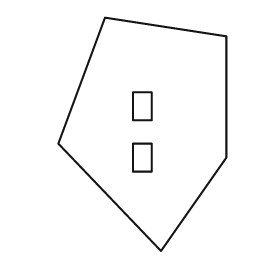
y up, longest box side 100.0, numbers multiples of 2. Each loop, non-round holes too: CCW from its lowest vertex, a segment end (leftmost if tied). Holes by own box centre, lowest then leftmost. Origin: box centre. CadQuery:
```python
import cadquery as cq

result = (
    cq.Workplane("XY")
    .moveTo(8.0, -50.0)
    .lineTo(36.0, -10.0)
    .lineTo(36.0, 42.0)
    .lineTo(-16.0, 50.0)
    .lineTo(-36.0, -4.0)
    .close()
    .moveTo(-4.0, -16.0)
    .lineTo(4.0, -16.0)
    .lineTo(4.0, -4.0)
    .lineTo(-4.0, -4.0)
    .close()
    .moveTo(-4.0, 6.0)
    .lineTo(4.0, 6.0)
    .lineTo(4.0, 18.0)
    .lineTo(-4.0, 18.0)
    .close()
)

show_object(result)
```